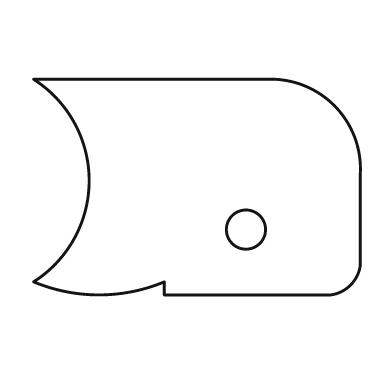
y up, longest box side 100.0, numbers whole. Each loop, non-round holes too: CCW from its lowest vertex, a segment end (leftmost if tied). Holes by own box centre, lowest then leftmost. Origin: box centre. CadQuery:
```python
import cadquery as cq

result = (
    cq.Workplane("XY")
    .moveTo(-10.0, -33.0)
    .lineTo(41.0, -33.0)
    .threePointArc((47.0, -30.0), (50.0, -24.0))
    .lineTo(50.0, 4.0)
    .threePointArc((42.0, 25.0), (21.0, 33.0))
    .lineTo(-50.0, 33.0)
    .threePointArc((-33.0, 2.0), (-50.0, -29.0))
    .threePointArc((-30.0, -33.0), (-10.0, -29.0))
    .close()
    .moveTo(15.0, -13.0)
    .circle(6.0)
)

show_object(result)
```